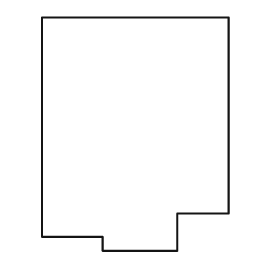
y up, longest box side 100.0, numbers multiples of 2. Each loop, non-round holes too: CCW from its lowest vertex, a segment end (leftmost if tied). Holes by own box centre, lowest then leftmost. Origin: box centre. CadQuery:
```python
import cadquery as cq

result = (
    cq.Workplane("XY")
    .moveTo(-14.0, -50.0)
    .lineTo(18.0, -50.0)
    .lineTo(18.0, -34.0)
    .lineTo(40.0, -34.0)
    .lineTo(40.0, 50.0)
    .lineTo(-40.0, 50.0)
    .lineTo(-40.0, -44.0)
    .lineTo(-14.0, -44.0)
    .close()
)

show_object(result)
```